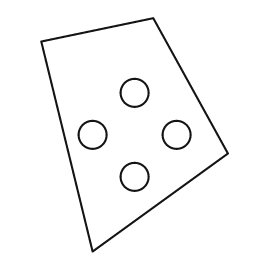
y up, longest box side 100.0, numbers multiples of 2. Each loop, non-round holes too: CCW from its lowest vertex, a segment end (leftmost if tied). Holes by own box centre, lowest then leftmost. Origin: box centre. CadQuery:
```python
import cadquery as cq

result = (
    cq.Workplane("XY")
    .moveTo(-18.0, -50.0)
    .lineTo(40.0, -8.0)
    .lineTo(8.0, 50.0)
    .lineTo(-40.0, 40.0)
    .close()
    .moveTo(0.0, -18.0)
    .circle(6.0)
    .moveTo(-18.0, 0.0)
    .circle(6.0)
    .moveTo(18.0, 0.0)
    .circle(6.0)
    .moveTo(0.0, 18.0)
    .circle(6.0)
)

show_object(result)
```